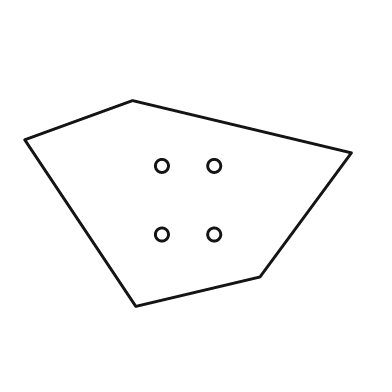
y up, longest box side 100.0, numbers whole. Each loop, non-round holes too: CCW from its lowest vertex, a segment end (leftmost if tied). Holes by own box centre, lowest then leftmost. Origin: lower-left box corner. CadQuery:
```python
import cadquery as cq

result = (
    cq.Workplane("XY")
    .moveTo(34.0, 0.0)
    .lineTo(72.0, 9.0)
    .lineTo(100.0, 47.0)
    .lineTo(33.0, 63.0)
    .lineTo(0.0, 51.0)
    .close()
    .moveTo(42.0, 22.0)
    .circle(2.0)
    .moveTo(58.0, 22.0)
    .circle(2.0)
    .moveTo(42.0, 43.0)
    .circle(2.0)
    .moveTo(58.0, 43.0)
    .circle(2.0)
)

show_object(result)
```